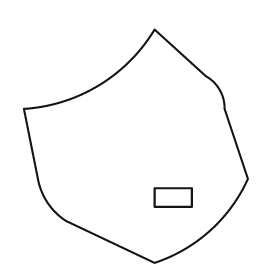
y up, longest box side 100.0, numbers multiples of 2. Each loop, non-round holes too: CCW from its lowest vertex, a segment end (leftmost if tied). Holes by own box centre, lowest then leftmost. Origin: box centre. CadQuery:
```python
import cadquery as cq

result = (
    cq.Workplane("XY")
    .moveTo(8.0, -50.0)
    .threePointArc((32.0, -36.0), (48.0, -14.0))
    .lineTo(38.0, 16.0)
    .threePointArc((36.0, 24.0), (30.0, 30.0))
    .lineTo(8.0, 50.0)
    .threePointArc((-16.0, 26.0), (-48.0, 16.0))
    .lineTo(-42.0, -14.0)
    .threePointArc((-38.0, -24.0), (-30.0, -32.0))
    .close()
    .moveTo(8.0, -26.0)
    .lineTo(24.0, -26.0)
    .lineTo(24.0, -18.0)
    .lineTo(8.0, -18.0)
    .close()
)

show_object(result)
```